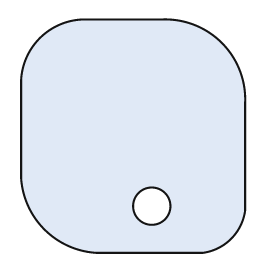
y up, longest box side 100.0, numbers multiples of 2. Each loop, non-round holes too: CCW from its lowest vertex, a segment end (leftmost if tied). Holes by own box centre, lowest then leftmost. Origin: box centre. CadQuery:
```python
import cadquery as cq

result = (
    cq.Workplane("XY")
    .moveTo(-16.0, -50.0)
    .lineTo(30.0, -50.0)
    .threePointArc((42.0, -44.0), (48.0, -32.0))
    .lineTo(48.0, 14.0)
    .threePointArc((38.0, 40.0), (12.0, 50.0))
    .lineTo(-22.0, 50.0)
    .threePointArc((-40.0, 42.0), (-48.0, 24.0))
    .lineTo(-48.0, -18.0)
    .threePointArc((-38.0, -40.0), (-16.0, -50.0))
    .close()
    .moveTo(8.0, -30.0)
    .circle(8.0)
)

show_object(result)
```